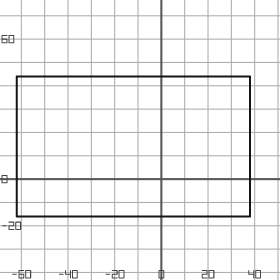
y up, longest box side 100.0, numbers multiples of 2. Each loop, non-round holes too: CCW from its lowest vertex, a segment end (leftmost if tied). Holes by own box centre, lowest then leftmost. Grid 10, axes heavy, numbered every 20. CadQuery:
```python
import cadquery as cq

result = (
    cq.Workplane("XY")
    .moveTo(-62.0, -16.0)
    .lineTo(38.0, -16.0)
    .lineTo(38.0, 44.0)
    .lineTo(-62.0, 44.0)
    .close()
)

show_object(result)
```